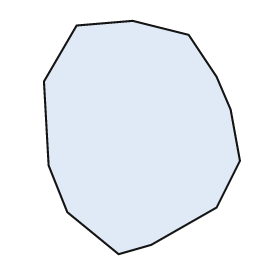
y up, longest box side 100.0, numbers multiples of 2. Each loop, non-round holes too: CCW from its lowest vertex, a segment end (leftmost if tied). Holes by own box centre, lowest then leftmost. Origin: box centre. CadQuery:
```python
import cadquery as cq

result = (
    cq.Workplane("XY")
    .moveTo(-10.0, -50.0)
    .lineTo(4.0, -46.0)
    .lineTo(32.0, -30.0)
    .lineTo(42.0, -10.0)
    .lineTo(38.0, 12.0)
    .lineTo(32.0, 26.0)
    .lineTo(20.0, 44.0)
    .lineTo(-4.0, 50.0)
    .lineTo(-28.0, 48.0)
    .lineTo(-42.0, 24.0)
    .lineTo(-40.0, -12.0)
    .lineTo(-32.0, -32.0)
    .close()
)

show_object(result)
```